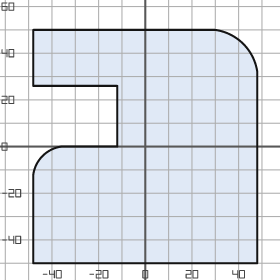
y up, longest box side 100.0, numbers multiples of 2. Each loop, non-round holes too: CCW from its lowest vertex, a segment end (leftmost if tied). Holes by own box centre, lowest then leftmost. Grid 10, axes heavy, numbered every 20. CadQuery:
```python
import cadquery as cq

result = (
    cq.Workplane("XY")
    .moveTo(-48.0, -50.0)
    .lineTo(48.0, -50.0)
    .lineTo(48.0, 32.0)
    .threePointArc((42.0, 44.0), (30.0, 50.0))
    .lineTo(-48.0, 50.0)
    .lineTo(-48.0, 26.0)
    .lineTo(-12.0, 26.0)
    .lineTo(-12.0, 0.0)
    .lineTo(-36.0, 0.0)
    .threePointArc((-44.0, -4.0), (-48.0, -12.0))
    .close()
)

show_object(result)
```